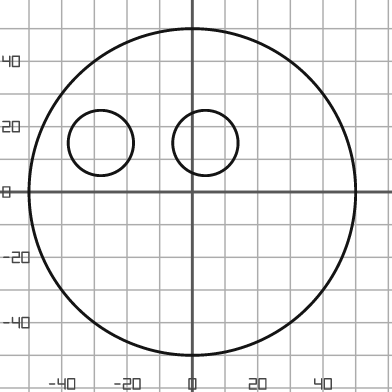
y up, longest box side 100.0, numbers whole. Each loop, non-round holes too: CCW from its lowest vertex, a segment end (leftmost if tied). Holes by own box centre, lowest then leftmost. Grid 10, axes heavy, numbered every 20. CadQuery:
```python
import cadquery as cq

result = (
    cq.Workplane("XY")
    .moveTo(0.0, 0.0)
    .circle(50.0)
    .moveTo(-28.0, 15.0)
    .circle(10.0)
    .moveTo(4.0, 15.0)
    .circle(10.0)
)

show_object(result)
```